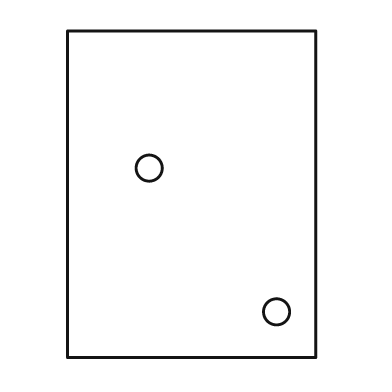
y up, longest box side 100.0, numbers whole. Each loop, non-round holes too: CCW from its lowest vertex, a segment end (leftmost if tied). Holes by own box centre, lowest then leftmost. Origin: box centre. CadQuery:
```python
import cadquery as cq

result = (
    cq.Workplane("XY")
    .moveTo(-38.0, -50.0)
    .lineTo(38.0, -50.0)
    .lineTo(38.0, 50.0)
    .lineTo(-38.0, 50.0)
    .close()
    .moveTo(26.0, -36.0)
    .circle(4.0)
    .moveTo(-13.0, 8.0)
    .circle(4.0)
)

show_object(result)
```